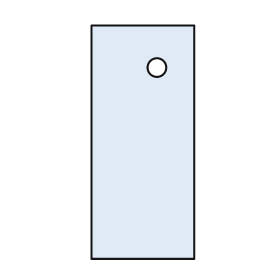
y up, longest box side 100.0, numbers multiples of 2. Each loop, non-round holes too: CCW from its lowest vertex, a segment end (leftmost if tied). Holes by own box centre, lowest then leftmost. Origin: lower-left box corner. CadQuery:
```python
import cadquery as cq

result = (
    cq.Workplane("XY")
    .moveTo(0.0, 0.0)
    .lineTo(44.0, 0.0)
    .lineTo(44.0, 100.0)
    .lineTo(0.0, 100.0)
    .close()
    .moveTo(28.0, 82.0)
    .circle(4.0)
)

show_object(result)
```